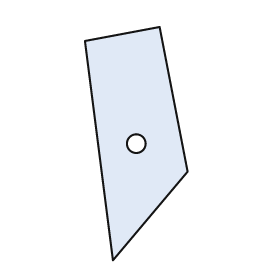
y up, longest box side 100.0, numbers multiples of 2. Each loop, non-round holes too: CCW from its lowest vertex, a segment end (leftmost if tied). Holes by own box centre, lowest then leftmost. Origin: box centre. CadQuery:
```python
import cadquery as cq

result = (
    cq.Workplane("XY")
    .moveTo(-10.0, -50.0)
    .lineTo(22.0, -12.0)
    .lineTo(10.0, 50.0)
    .lineTo(-22.0, 44.0)
    .close()
    .moveTo(0.0, 0.0)
    .circle(4.0)
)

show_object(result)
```